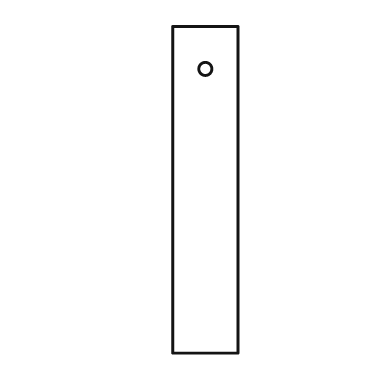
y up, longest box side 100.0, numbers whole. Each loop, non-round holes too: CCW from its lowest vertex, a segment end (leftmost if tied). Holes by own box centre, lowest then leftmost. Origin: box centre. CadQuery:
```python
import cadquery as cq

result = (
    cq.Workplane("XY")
    .moveTo(-10.0, -50.0)
    .lineTo(10.0, -50.0)
    .lineTo(10.0, 50.0)
    .lineTo(-10.0, 50.0)
    .close()
    .moveTo(0.0, 37.0)
    .circle(2.0)
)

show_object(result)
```